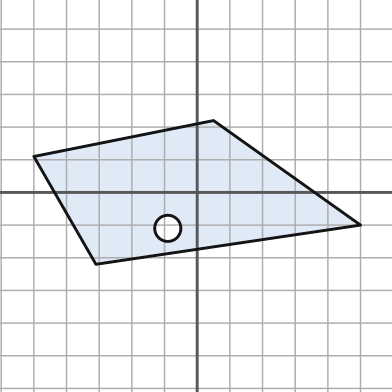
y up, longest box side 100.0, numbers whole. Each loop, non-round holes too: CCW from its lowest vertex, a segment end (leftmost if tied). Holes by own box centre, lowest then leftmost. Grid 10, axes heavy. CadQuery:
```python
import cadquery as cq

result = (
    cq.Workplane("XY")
    .moveTo(-31.0, -22.0)
    .lineTo(50.0, -10.0)
    .lineTo(5.0, 22.0)
    .lineTo(-50.0, 11.0)
    .close()
    .moveTo(-9.0, -11.0)
    .circle(4.0)
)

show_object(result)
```